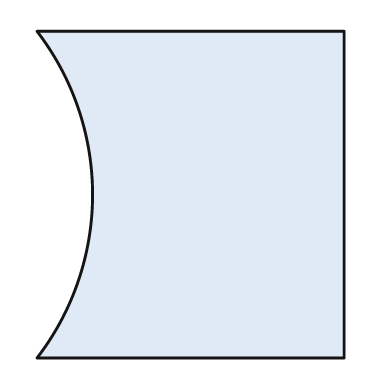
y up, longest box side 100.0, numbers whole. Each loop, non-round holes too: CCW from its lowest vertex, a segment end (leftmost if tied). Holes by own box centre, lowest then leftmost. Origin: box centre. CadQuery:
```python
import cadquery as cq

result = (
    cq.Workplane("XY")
    .moveTo(-47.0, -50.0)
    .lineTo(47.0, -50.0)
    .lineTo(47.0, 50.0)
    .lineTo(-47.0, 50.0)
    .threePointArc((-30.0, 0.0), (-47.0, -50.0))
    .close()
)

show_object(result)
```